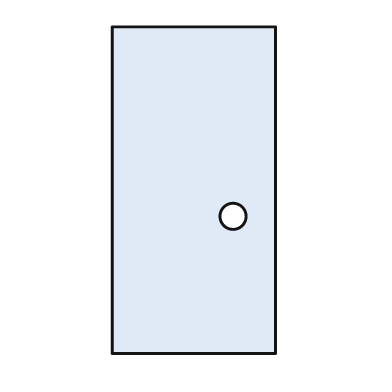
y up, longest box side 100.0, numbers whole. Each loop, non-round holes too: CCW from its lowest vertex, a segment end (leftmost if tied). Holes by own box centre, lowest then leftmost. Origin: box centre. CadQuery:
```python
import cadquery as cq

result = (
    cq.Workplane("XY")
    .moveTo(-25.0, -50.0)
    .lineTo(25.0, -50.0)
    .lineTo(25.0, 50.0)
    .lineTo(-25.0, 50.0)
    .close()
    .moveTo(12.0, -8.0)
    .circle(4.0)
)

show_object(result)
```